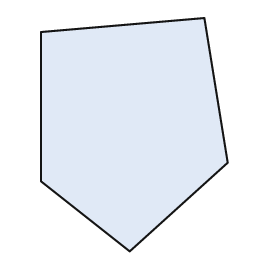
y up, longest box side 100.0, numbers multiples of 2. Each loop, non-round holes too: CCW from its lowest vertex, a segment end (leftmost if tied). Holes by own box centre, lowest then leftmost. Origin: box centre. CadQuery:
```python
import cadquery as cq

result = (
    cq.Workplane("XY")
    .moveTo(-2.0, -50.0)
    .lineTo(40.0, -12.0)
    .lineTo(30.0, 50.0)
    .lineTo(-40.0, 44.0)
    .lineTo(-40.0, -20.0)
    .close()
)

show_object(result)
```